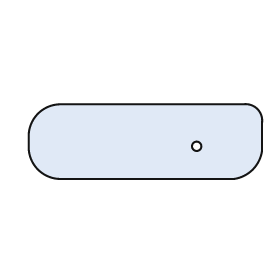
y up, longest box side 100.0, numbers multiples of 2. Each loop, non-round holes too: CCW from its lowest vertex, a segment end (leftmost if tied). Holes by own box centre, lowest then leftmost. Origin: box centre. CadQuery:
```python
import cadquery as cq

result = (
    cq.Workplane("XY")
    .moveTo(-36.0, -16.0)
    .lineTo(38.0, -16.0)
    .threePointArc((46.0, -12.0), (50.0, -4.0))
    .lineTo(50.0, 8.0)
    .threePointArc((48.0, 14.0), (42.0, 16.0))
    .lineTo(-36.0, 16.0)
    .threePointArc((-46.0, 12.0), (-50.0, 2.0))
    .lineTo(-50.0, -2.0)
    .threePointArc((-46.0, -12.0), (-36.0, -16.0))
    .close()
    .moveTo(22.0, -2.0)
    .circle(2.0)
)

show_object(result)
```